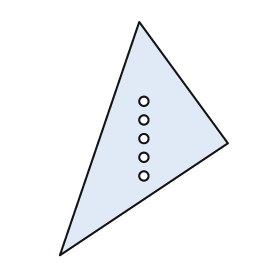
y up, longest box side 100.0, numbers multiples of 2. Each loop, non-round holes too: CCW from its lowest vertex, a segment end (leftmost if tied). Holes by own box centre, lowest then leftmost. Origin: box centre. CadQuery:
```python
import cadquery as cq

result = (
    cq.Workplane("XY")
    .moveTo(-36.0, -50.0)
    .lineTo(36.0, -2.0)
    .lineTo(-2.0, 50.0)
    .close()
    .moveTo(0.0, -16.0)
    .circle(2.0)
    .moveTo(0.0, -8.0)
    .circle(2.0)
    .moveTo(0.0, 0.0)
    .circle(2.0)
    .moveTo(0.0, 8.0)
    .circle(2.0)
    .moveTo(0.0, 16.0)
    .circle(2.0)
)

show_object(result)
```